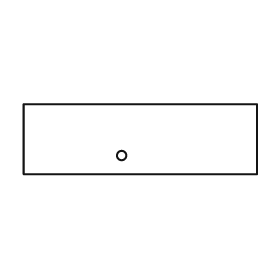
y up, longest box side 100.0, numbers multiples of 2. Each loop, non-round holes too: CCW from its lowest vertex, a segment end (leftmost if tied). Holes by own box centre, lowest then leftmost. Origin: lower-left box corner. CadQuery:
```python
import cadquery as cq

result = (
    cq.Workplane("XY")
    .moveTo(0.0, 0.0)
    .lineTo(100.0, 0.0)
    .lineTo(100.0, 30.0)
    .lineTo(0.0, 30.0)
    .close()
    .moveTo(42.0, 8.0)
    .circle(2.0)
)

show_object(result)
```